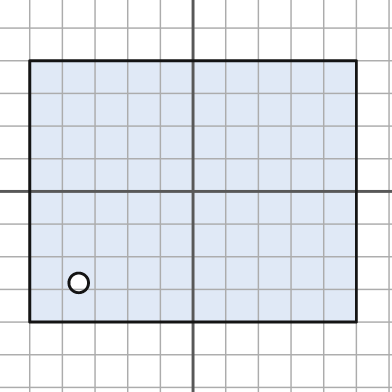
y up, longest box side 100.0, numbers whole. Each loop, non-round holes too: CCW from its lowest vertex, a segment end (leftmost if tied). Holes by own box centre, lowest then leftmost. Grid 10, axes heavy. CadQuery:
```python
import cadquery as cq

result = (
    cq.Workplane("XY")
    .moveTo(-50.0, -40.0)
    .lineTo(50.0, -40.0)
    .lineTo(50.0, 40.0)
    .lineTo(-50.0, 40.0)
    .close()
    .moveTo(-35.0, -28.0)
    .circle(3.0)
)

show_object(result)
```